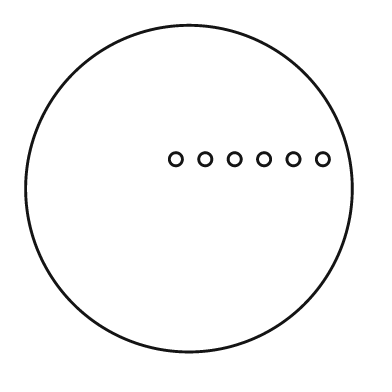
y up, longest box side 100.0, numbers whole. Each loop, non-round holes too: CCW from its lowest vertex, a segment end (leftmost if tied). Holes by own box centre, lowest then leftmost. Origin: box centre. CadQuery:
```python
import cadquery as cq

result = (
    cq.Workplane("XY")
    .moveTo(0.0, 0.0)
    .circle(50.0)
    .moveTo(-4.0, 9.0)
    .circle(2.0)
    .moveTo(5.0, 9.0)
    .circle(2.0)
    .moveTo(14.0, 9.0)
    .circle(2.0)
    .moveTo(23.0, 9.0)
    .circle(2.0)
    .moveTo(32.0, 9.0)
    .circle(2.0)
    .moveTo(41.0, 9.0)
    .circle(2.0)
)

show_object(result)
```